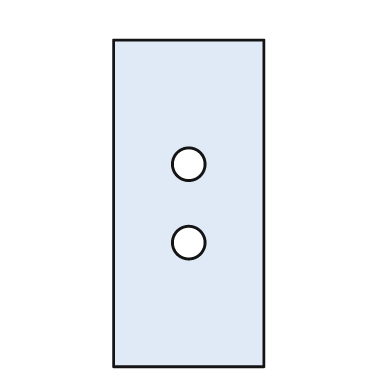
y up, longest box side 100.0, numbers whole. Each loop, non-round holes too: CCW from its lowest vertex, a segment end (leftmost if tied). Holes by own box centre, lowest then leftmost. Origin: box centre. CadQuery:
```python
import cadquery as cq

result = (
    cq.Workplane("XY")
    .moveTo(-23.0, -50.0)
    .lineTo(23.0, -50.0)
    .lineTo(23.0, 50.0)
    .lineTo(-23.0, 50.0)
    .close()
    .moveTo(0.0, -12.0)
    .circle(5.0)
    .moveTo(0.0, 12.0)
    .circle(5.0)
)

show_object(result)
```